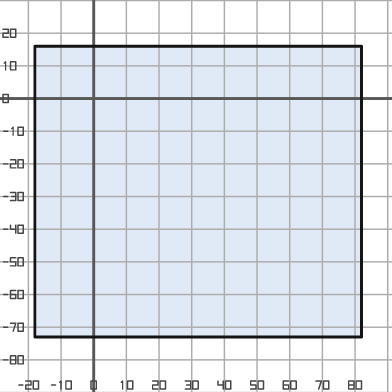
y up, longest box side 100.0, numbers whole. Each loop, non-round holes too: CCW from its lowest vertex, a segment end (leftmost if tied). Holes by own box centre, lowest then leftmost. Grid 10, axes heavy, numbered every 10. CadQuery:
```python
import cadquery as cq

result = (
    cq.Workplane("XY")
    .moveTo(-18.0, -73.0)
    .lineTo(82.0, -73.0)
    .lineTo(82.0, 16.0)
    .lineTo(-18.0, 16.0)
    .close()
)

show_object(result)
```